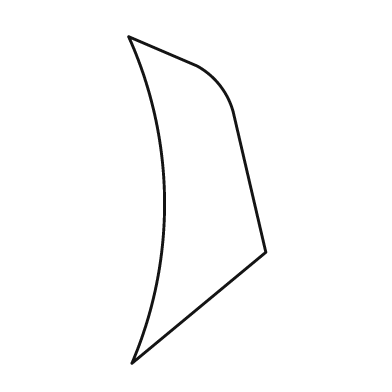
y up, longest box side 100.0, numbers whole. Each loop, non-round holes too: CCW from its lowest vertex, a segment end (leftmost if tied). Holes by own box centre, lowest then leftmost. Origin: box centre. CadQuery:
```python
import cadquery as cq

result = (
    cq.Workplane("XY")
    .moveTo(-20.0, -50.0)
    .lineTo(21.0, -16.0)
    .lineTo(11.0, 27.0)
    .threePointArc((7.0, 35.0), (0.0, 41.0))
    .lineTo(-21.0, 50.0)
    .threePointArc((-10.0, 0.0), (-20.0, -50.0))
    .close()
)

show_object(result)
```